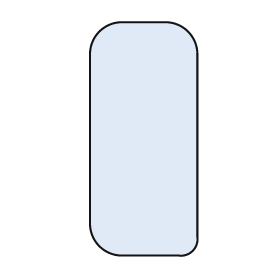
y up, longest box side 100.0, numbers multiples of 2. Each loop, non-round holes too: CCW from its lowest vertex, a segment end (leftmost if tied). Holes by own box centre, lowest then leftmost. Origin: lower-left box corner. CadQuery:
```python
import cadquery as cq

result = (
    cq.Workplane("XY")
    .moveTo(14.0, 0.0)
    .lineTo(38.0, 0.0)
    .threePointArc((44.0, 2.0), (46.0, 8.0))
    .lineTo(46.0, 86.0)
    .threePointArc((42.0, 96.0), (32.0, 100.0))
    .lineTo(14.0, 100.0)
    .threePointArc((4.0, 96.0), (0.0, 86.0))
    .lineTo(0.0, 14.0)
    .threePointArc((4.0, 4.0), (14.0, 0.0))
    .close()
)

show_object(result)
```